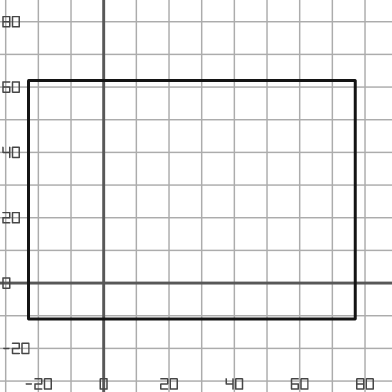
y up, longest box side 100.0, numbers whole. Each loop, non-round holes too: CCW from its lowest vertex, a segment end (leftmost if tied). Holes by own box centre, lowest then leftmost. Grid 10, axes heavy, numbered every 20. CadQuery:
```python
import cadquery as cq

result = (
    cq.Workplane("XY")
    .moveTo(-23.0, -11.0)
    .lineTo(77.0, -11.0)
    .lineTo(77.0, 62.0)
    .lineTo(-23.0, 62.0)
    .close()
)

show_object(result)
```